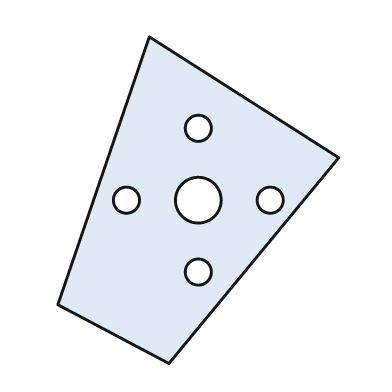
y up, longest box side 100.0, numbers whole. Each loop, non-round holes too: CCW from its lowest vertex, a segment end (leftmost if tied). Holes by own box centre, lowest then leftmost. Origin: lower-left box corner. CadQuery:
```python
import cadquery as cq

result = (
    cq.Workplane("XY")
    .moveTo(34.0, 0.0)
    .lineTo(86.0, 63.0)
    .lineTo(28.0, 100.0)
    .lineTo(0.0, 18.0)
    .close()
    .moveTo(43.0, 28.0)
    .circle(4.0)
    .moveTo(21.0, 50.0)
    .circle(4.0)
    .moveTo(43.0, 50.0)
    .circle(7.0)
    .moveTo(65.0, 50.0)
    .circle(4.0)
    .moveTo(43.0, 72.0)
    .circle(4.0)
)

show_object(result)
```